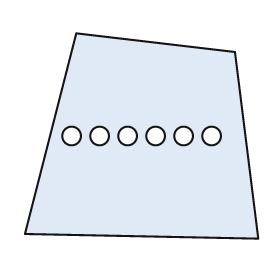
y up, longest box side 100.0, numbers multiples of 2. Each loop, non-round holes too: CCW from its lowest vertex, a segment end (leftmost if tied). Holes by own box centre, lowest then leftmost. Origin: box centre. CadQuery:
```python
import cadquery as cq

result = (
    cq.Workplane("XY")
    .moveTo(50.0, -44.0)
    .lineTo(40.0, 36.0)
    .lineTo(-28.0, 44.0)
    .lineTo(-50.0, -42.0)
    .close()
    .moveTo(-30.0, 0.0)
    .circle(4.0)
    .moveTo(-18.0, 0.0)
    .circle(4.0)
    .moveTo(-6.0, 0.0)
    .circle(4.0)
    .moveTo(6.0, 0.0)
    .circle(4.0)
    .moveTo(18.0, 0.0)
    .circle(4.0)
    .moveTo(30.0, 0.0)
    .circle(4.0)
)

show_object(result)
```